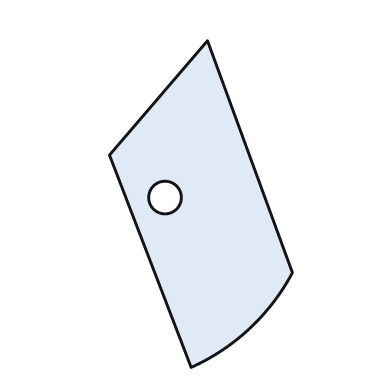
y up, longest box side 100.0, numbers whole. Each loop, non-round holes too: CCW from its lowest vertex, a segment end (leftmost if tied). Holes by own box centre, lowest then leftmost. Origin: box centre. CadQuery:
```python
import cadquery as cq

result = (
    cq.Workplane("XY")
    .moveTo(-3.0, -50.0)
    .threePointArc((15.0, -38.0), (28.0, -21.0))
    .lineTo(2.0, 50.0)
    .lineTo(-28.0, 15.0)
    .close()
    .moveTo(-11.0, 2.0)
    .circle(5.0)
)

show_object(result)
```